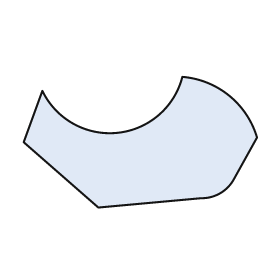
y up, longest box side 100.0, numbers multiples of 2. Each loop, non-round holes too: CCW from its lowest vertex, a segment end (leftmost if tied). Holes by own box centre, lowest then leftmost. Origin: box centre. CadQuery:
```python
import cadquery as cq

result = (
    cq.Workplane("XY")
    .moveTo(-18.0, -28.0)
    .lineTo(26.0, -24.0)
    .threePointArc((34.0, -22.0), (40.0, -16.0))
    .lineTo(50.0, 2.0)
    .threePointArc((38.0, 20.0), (18.0, 28.0))
    .threePointArc((-10.0, 4.0), (-42.0, 22.0))
    .lineTo(-50.0, 0.0)
    .close()
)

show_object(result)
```